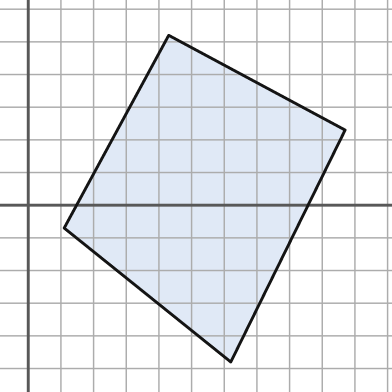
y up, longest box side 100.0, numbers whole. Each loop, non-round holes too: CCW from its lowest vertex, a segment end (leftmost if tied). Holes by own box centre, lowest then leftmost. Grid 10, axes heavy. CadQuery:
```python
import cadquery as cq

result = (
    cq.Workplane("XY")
    .moveTo(62.0, -48.0)
    .lineTo(97.0, 23.0)
    .lineTo(43.0, 52.0)
    .lineTo(11.0, -7.0)
    .close()
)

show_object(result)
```